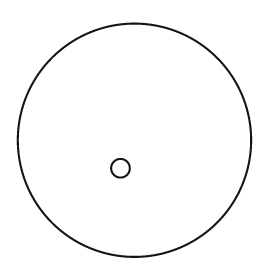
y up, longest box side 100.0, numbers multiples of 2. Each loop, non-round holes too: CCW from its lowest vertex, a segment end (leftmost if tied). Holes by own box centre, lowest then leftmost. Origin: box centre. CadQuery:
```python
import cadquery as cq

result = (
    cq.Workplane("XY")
    .moveTo(0.0, 0.0)
    .circle(50.0)
    .moveTo(-6.0, -12.0)
    .circle(4.0)
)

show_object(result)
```